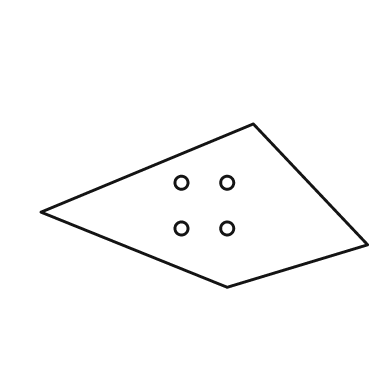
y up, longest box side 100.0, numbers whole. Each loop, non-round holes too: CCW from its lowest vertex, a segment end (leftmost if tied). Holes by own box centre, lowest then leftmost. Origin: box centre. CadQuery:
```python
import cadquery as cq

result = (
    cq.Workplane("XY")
    .moveTo(7.0, -25.0)
    .lineTo(50.0, -12.0)
    .lineTo(15.0, 25.0)
    .lineTo(-50.0, -2.0)
    .close()
    .moveTo(-7.0, -7.0)
    .circle(2.0)
    .moveTo(7.0, -7.0)
    .circle(2.0)
    .moveTo(-7.0, 7.0)
    .circle(2.0)
    .moveTo(7.0, 7.0)
    .circle(2.0)
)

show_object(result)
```